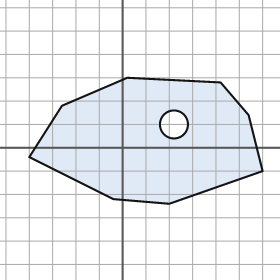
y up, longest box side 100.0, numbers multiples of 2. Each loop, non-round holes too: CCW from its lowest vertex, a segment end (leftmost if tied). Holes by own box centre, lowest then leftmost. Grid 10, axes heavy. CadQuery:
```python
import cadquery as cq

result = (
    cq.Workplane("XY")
    .moveTo(20.0, -24.0)
    .lineTo(60.0, -10.0)
    .lineTo(54.0, 14.0)
    .lineTo(42.0, 28.0)
    .lineTo(2.0, 30.0)
    .lineTo(-26.0, 18.0)
    .lineTo(-40.0, -4.0)
    .lineTo(-4.0, -22.0)
    .close()
    .moveTo(22.0, 10.0)
    .circle(6.0)
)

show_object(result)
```